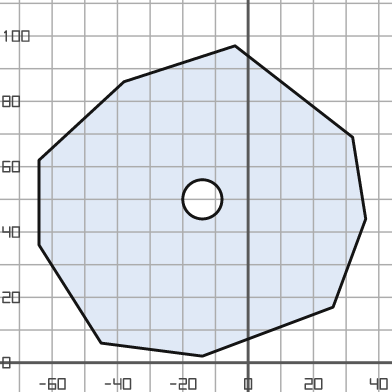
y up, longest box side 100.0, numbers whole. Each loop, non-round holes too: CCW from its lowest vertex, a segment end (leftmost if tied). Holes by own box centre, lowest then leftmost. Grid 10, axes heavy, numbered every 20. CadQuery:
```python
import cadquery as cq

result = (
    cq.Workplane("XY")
    .moveTo(-14.0, 2.0)
    .lineTo(26.0, 17.0)
    .lineTo(36.0, 44.0)
    .lineTo(32.0, 69.0)
    .lineTo(-4.0, 97.0)
    .lineTo(-38.0, 86.0)
    .lineTo(-64.0, 62.0)
    .lineTo(-64.0, 36.0)
    .lineTo(-45.0, 6.0)
    .close()
    .moveTo(-14.0, 50.0)
    .circle(6.0)
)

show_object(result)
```